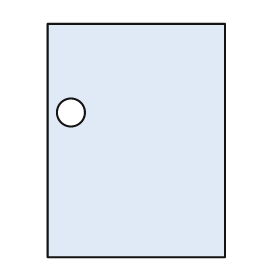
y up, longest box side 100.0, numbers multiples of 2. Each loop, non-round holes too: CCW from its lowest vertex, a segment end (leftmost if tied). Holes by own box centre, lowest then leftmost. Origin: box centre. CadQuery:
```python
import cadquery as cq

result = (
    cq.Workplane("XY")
    .moveTo(-38.0, -50.0)
    .lineTo(38.0, -50.0)
    .lineTo(38.0, 50.0)
    .lineTo(-38.0, 50.0)
    .close()
    .moveTo(-28.0, 12.0)
    .circle(6.0)
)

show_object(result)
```